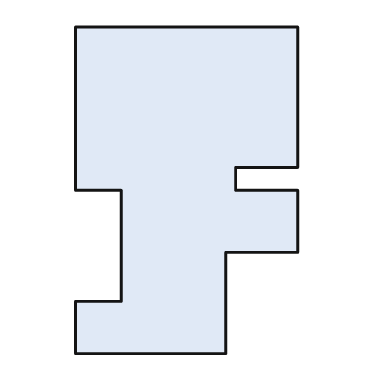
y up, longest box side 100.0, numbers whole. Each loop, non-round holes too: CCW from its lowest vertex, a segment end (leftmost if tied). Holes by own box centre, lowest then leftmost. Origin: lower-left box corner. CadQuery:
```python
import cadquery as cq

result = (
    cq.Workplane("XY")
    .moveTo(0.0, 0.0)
    .lineTo(46.0, 0.0)
    .lineTo(46.0, 31.0)
    .lineTo(68.0, 31.0)
    .lineTo(68.0, 50.0)
    .lineTo(49.0, 50.0)
    .lineTo(49.0, 57.0)
    .lineTo(68.0, 57.0)
    .lineTo(68.0, 100.0)
    .lineTo(0.0, 100.0)
    .lineTo(0.0, 50.0)
    .lineTo(14.0, 50.0)
    .lineTo(14.0, 16.0)
    .lineTo(0.0, 16.0)
    .close()
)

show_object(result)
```